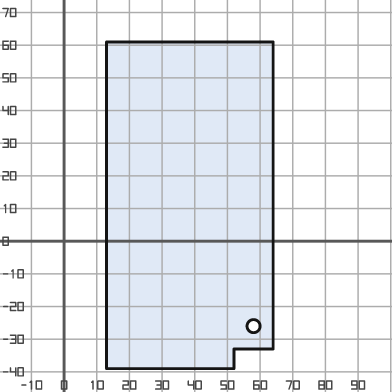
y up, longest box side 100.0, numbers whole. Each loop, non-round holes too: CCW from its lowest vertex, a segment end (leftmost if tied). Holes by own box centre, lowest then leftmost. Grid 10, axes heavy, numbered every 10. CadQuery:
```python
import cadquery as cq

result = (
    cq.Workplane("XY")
    .moveTo(13.0, -39.0)
    .lineTo(52.0, -39.0)
    .lineTo(52.0, -33.0)
    .lineTo(64.0, -33.0)
    .lineTo(64.0, 61.0)
    .lineTo(13.0, 61.0)
    .close()
    .moveTo(58.0, -26.0)
    .circle(2.0)
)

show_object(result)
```